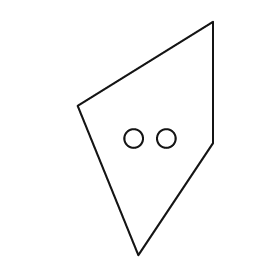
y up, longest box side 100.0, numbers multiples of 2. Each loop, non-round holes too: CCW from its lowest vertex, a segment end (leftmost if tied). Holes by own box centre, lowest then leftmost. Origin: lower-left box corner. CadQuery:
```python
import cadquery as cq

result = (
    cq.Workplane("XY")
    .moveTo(26.0, 0.0)
    .lineTo(58.0, 48.0)
    .lineTo(58.0, 100.0)
    .lineTo(0.0, 64.0)
    .close()
    .moveTo(24.0, 50.0)
    .circle(4.0)
    .moveTo(38.0, 50.0)
    .circle(4.0)
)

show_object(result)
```